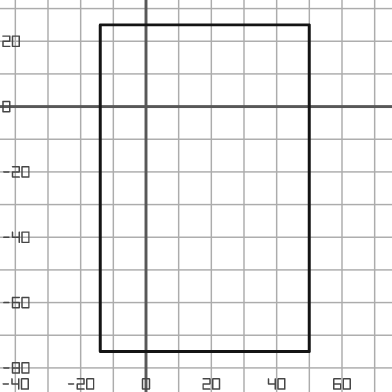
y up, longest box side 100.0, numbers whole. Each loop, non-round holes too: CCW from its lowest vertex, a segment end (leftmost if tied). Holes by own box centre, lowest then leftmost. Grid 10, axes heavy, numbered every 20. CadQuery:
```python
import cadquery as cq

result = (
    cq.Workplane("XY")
    .moveTo(-14.0, -75.0)
    .lineTo(50.0, -75.0)
    .lineTo(50.0, 25.0)
    .lineTo(-14.0, 25.0)
    .close()
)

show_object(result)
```